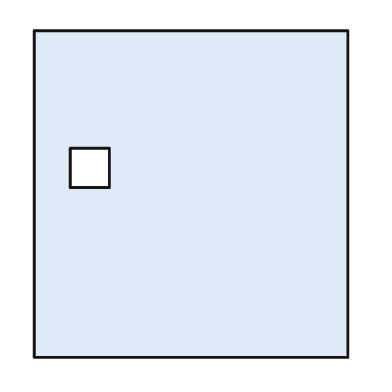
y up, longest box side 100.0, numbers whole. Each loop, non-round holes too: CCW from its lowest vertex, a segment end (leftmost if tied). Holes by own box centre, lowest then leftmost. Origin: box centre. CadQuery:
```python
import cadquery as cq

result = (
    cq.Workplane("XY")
    .moveTo(-48.0, -50.0)
    .lineTo(48.0, -50.0)
    .lineTo(48.0, 50.0)
    .lineTo(-48.0, 50.0)
    .close()
    .moveTo(-37.0, 2.0)
    .lineTo(-25.0, 2.0)
    .lineTo(-25.0, 14.0)
    .lineTo(-37.0, 14.0)
    .close()
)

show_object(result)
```